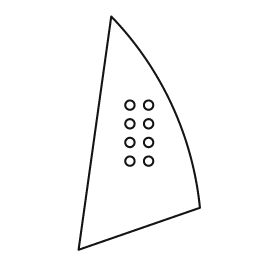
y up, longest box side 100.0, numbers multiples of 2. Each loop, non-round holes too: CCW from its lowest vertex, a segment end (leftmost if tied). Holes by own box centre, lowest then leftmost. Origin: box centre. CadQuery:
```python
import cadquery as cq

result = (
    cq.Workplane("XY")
    .moveTo(-26.0, -50.0)
    .lineTo(26.0, -32.0)
    .threePointArc((14.0, 12.0), (-12.0, 50.0))
    .close()
    .moveTo(-4.0, -12.0)
    .circle(2.0)
    .moveTo(4.0, -12.0)
    .circle(2.0)
    .moveTo(-4.0, -4.0)
    .circle(2.0)
    .moveTo(4.0, -4.0)
    .circle(2.0)
    .moveTo(-4.0, 4.0)
    .circle(2.0)
    .moveTo(4.0, 4.0)
    .circle(2.0)
    .moveTo(-4.0, 12.0)
    .circle(2.0)
    .moveTo(4.0, 12.0)
    .circle(2.0)
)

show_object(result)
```